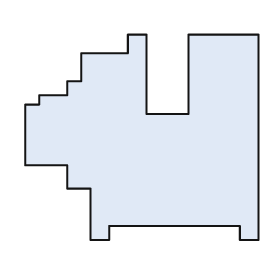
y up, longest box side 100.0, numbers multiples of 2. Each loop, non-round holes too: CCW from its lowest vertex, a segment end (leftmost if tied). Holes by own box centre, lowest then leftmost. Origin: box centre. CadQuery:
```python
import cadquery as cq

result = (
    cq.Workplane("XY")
    .moveTo(-22.0, -44.0)
    .lineTo(-14.0, -44.0)
    .lineTo(-14.0, -38.0)
    .lineTo(42.0, -38.0)
    .lineTo(42.0, -44.0)
    .lineTo(50.0, -44.0)
    .lineTo(50.0, 44.0)
    .lineTo(20.0, 44.0)
    .lineTo(20.0, 10.0)
    .lineTo(2.0, 10.0)
    .lineTo(2.0, 44.0)
    .lineTo(-6.0, 44.0)
    .lineTo(-6.0, 36.0)
    .lineTo(-26.0, 36.0)
    .lineTo(-26.0, 24.0)
    .lineTo(-32.0, 24.0)
    .lineTo(-32.0, 18.0)
    .lineTo(-44.0, 18.0)
    .lineTo(-44.0, 14.0)
    .lineTo(-50.0, 14.0)
    .lineTo(-50.0, -12.0)
    .lineTo(-32.0, -12.0)
    .lineTo(-32.0, -22.0)
    .lineTo(-22.0, -22.0)
    .close()
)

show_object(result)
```